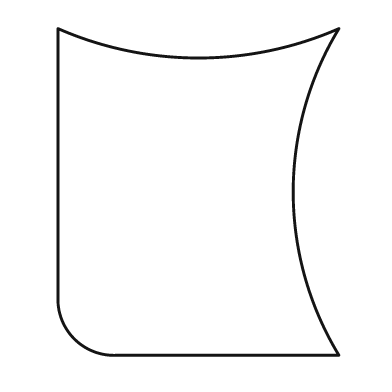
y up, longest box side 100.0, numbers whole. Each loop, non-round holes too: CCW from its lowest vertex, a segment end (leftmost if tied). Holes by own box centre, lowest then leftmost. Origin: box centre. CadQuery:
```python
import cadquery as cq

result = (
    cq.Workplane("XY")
    .moveTo(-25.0, -50.0)
    .lineTo(43.0, -50.0)
    .threePointArc((29.0, 0.0), (43.0, 50.0))
    .threePointArc((0.0, 41.0), (-43.0, 50.0))
    .lineTo(-43.0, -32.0)
    .threePointArc((-38.0, -45.0), (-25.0, -50.0))
    .close()
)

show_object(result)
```